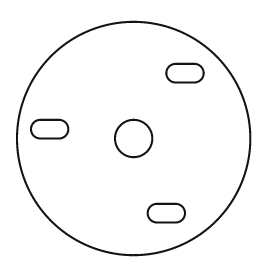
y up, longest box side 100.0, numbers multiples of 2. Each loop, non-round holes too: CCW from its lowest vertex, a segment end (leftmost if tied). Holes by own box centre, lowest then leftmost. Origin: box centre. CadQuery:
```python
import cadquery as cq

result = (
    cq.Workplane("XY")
    .moveTo(0.0, 0.0)
    .circle(50.0)
    .moveTo(10.0, -36.0)
    .lineTo(18.0, -36.0)
    .threePointArc((22.0, -32.0), (18.0, -28.0))
    .lineTo(10.0, -28.0)
    .threePointArc((6.0, -32.0), (10.0, -36.0))
    .close()
    .moveTo(0.0, 0.0)
    .circle(8.0)
    .moveTo(-40.0, 0.0)
    .lineTo(-32.0, 0.0)
    .threePointArc((-28.0, 4.0), (-32.0, 8.0))
    .lineTo(-40.0, 8.0)
    .threePointArc((-44.0, 4.0), (-40.0, 0.0))
    .close()
    .moveTo(18.0, 24.0)
    .lineTo(26.0, 24.0)
    .threePointArc((30.0, 28.0), (26.0, 32.0))
    .lineTo(18.0, 32.0)
    .threePointArc((14.0, 28.0), (18.0, 24.0))
    .close()
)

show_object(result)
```